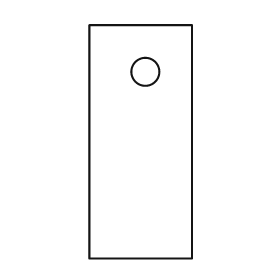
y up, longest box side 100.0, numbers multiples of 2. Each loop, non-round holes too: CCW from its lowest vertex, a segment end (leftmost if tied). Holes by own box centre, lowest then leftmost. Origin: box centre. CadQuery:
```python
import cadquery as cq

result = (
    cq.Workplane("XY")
    .moveTo(-22.0, -50.0)
    .lineTo(22.0, -50.0)
    .lineTo(22.0, 50.0)
    .lineTo(-22.0, 50.0)
    .close()
    .moveTo(2.0, 30.0)
    .circle(6.0)
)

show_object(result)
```